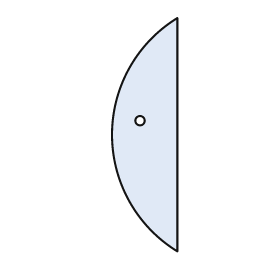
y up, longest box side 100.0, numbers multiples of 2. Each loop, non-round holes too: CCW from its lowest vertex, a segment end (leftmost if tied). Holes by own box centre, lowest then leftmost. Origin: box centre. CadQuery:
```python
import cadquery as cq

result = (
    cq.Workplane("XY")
    .moveTo(14.0, -50.0)
    .lineTo(14.0, 50.0)
    .threePointArc((-14.0, 0.0), (14.0, -50.0))
    .close()
    .moveTo(-2.0, 6.0)
    .circle(2.0)
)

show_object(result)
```